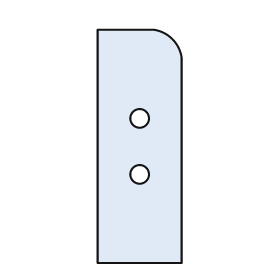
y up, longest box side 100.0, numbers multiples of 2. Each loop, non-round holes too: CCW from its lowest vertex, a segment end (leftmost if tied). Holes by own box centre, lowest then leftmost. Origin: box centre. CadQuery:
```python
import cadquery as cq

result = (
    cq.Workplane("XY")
    .moveTo(-18.0, -50.0)
    .lineTo(18.0, -50.0)
    .lineTo(18.0, 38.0)
    .threePointArc((14.0, 46.0), (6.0, 50.0))
    .lineTo(-18.0, 50.0)
    .close()
    .moveTo(0.0, -12.0)
    .circle(4.0)
    .moveTo(0.0, 12.0)
    .circle(4.0)
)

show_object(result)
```